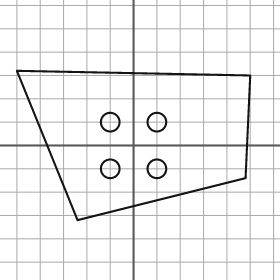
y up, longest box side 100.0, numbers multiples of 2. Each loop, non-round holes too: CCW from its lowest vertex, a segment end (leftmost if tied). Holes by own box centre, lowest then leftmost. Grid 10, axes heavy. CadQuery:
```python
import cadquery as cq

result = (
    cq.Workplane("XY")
    .moveTo(-24.0, -32.0)
    .lineTo(48.0, -14.0)
    .lineTo(50.0, 30.0)
    .lineTo(-50.0, 32.0)
    .close()
    .moveTo(-10.0, -10.0)
    .circle(4.0)
    .moveTo(10.0, -10.0)
    .circle(4.0)
    .moveTo(-10.0, 10.0)
    .circle(4.0)
    .moveTo(10.0, 10.0)
    .circle(4.0)
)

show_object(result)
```